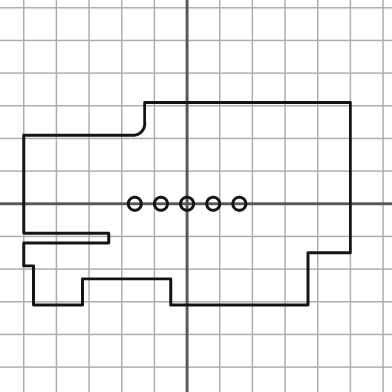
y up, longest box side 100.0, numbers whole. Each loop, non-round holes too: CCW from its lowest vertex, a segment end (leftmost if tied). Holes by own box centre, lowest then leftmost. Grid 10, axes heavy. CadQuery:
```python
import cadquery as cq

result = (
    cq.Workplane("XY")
    .moveTo(-47.0, -31.0)
    .lineTo(-32.0, -31.0)
    .lineTo(-32.0, -23.0)
    .lineTo(-5.0, -23.0)
    .lineTo(-5.0, -31.0)
    .lineTo(37.0, -31.0)
    .lineTo(37.0, -15.0)
    .lineTo(50.0, -15.0)
    .lineTo(50.0, 31.0)
    .lineTo(-13.0, 31.0)
    .lineTo(-13.0, 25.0)
    .threePointArc((-14.0, 22.0), (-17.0, 21.0))
    .lineTo(-50.0, 21.0)
    .lineTo(-50.0, -9.0)
    .lineTo(-24.0, -9.0)
    .lineTo(-24.0, -12.0)
    .lineTo(-50.0, -12.0)
    .lineTo(-50.0, -19.0)
    .lineTo(-47.0, -19.0)
    .close()
    .moveTo(-16.0, 0.0)
    .circle(2.0)
    .moveTo(-8.0, 0.0)
    .circle(2.0)
    .moveTo(0.0, 0.0)
    .circle(2.0)
    .moveTo(8.0, 0.0)
    .circle(2.0)
    .moveTo(16.0, 0.0)
    .circle(2.0)
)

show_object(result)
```